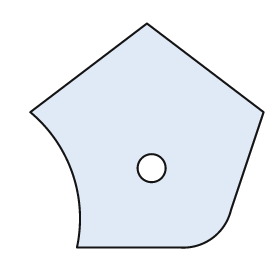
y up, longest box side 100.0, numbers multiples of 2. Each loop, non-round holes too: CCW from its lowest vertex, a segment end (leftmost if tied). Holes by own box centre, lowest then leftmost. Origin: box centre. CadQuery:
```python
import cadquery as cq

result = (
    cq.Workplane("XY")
    .moveTo(-30.0, -48.0)
    .lineTo(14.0, -48.0)
    .threePointArc((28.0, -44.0), (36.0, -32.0))
    .lineTo(50.0, 10.0)
    .lineTo(0.0, 48.0)
    .lineTo(-50.0, 10.0)
    .threePointArc((-32.0, -16.0), (-30.0, -48.0))
    .close()
    .moveTo(2.0, -14.0)
    .circle(6.0)
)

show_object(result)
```